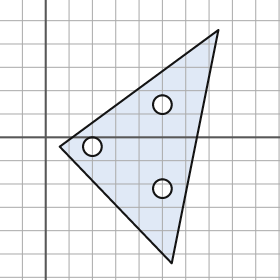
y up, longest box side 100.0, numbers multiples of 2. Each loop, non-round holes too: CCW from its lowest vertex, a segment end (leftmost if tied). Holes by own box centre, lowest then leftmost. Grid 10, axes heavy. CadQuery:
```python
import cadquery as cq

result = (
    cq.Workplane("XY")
    .moveTo(54.0, -54.0)
    .lineTo(74.0, 46.0)
    .lineTo(6.0, -4.0)
    .close()
    .moveTo(50.0, -22.0)
    .circle(4.0)
    .moveTo(20.0, -4.0)
    .circle(4.0)
    .moveTo(50.0, 14.0)
    .circle(4.0)
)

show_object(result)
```